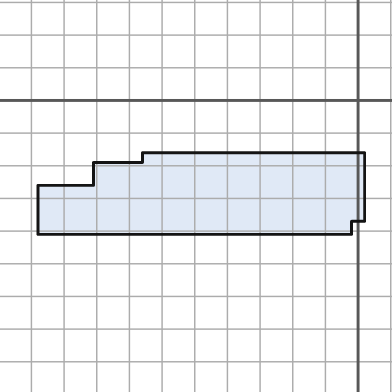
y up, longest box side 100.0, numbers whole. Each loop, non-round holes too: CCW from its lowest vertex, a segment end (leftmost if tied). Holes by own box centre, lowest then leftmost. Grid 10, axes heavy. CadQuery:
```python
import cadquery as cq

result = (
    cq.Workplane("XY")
    .moveTo(-98.0, -41.0)
    .lineTo(-2.0, -41.0)
    .lineTo(-2.0, -37.0)
    .lineTo(2.0, -37.0)
    .lineTo(2.0, -16.0)
    .lineTo(-66.0, -16.0)
    .lineTo(-66.0, -19.0)
    .lineTo(-81.0, -19.0)
    .lineTo(-81.0, -26.0)
    .lineTo(-98.0, -26.0)
    .close()
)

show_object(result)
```